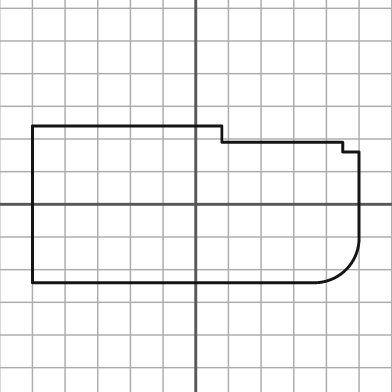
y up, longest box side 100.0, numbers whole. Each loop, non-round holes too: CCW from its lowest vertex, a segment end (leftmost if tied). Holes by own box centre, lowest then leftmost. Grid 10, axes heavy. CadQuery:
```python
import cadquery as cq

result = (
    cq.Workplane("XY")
    .moveTo(-50.0, -24.0)
    .lineTo(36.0, -24.0)
    .threePointArc((46.0, -20.0), (50.0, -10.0))
    .lineTo(50.0, 16.0)
    .lineTo(45.0, 16.0)
    .lineTo(45.0, 19.0)
    .lineTo(8.0, 19.0)
    .lineTo(8.0, 24.0)
    .lineTo(-50.0, 24.0)
    .close()
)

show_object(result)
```